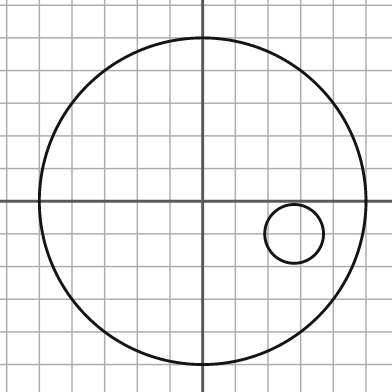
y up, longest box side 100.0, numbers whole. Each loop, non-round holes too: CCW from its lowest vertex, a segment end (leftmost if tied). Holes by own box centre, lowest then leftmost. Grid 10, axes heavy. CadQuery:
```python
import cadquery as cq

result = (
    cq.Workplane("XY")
    .moveTo(0.0, 0.0)
    .circle(50.0)
    .moveTo(28.0, -10.0)
    .circle(9.0)
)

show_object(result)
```